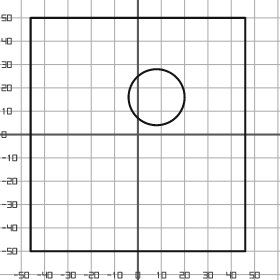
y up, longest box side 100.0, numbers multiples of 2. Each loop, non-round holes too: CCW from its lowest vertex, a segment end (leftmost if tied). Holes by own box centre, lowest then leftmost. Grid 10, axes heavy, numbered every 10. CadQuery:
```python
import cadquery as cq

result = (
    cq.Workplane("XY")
    .moveTo(-46.0, -50.0)
    .lineTo(46.0, -50.0)
    .lineTo(46.0, 50.0)
    .lineTo(-46.0, 50.0)
    .close()
    .moveTo(8.0, 16.0)
    .circle(12.0)
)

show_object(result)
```